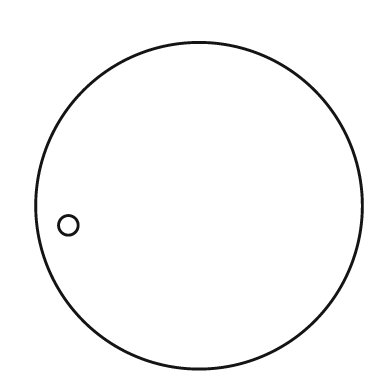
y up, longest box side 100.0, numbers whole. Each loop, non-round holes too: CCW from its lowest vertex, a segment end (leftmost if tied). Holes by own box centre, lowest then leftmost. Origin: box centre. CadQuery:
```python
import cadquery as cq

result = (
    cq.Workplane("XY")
    .moveTo(0.0, 0.0)
    .circle(50.0)
    .moveTo(-40.0, -6.0)
    .circle(3.0)
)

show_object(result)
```